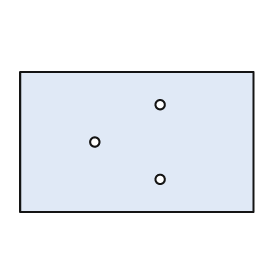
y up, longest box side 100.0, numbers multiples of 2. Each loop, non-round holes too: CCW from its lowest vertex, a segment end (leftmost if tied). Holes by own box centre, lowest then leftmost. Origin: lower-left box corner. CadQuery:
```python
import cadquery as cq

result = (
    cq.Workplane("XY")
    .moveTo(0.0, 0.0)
    .lineTo(100.0, 0.0)
    .lineTo(100.0, 60.0)
    .lineTo(0.0, 60.0)
    .close()
    .moveTo(60.0, 14.0)
    .circle(2.0)
    .moveTo(32.0, 30.0)
    .circle(2.0)
    .moveTo(60.0, 46.0)
    .circle(2.0)
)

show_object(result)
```